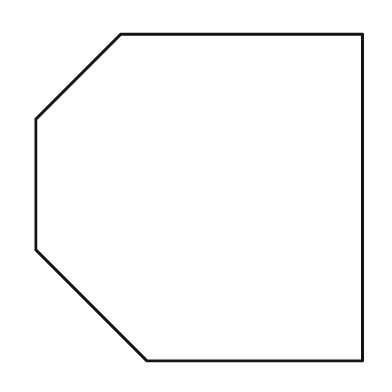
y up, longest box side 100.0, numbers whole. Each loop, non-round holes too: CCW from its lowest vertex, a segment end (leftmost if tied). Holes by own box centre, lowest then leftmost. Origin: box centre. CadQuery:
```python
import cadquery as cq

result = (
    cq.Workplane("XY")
    .moveTo(-16.0, -50.0)
    .lineTo(50.0, -50.0)
    .lineTo(50.0, 50.0)
    .lineTo(-24.0, 50.0)
    .lineTo(-50.0, 24.0)
    .lineTo(-50.0, -16.0)
    .close()
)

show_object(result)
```